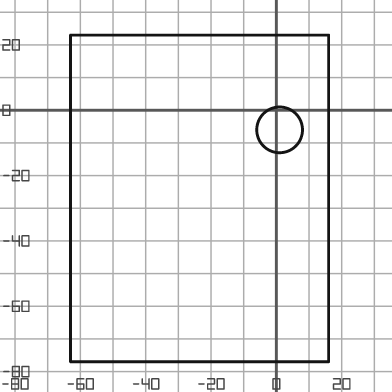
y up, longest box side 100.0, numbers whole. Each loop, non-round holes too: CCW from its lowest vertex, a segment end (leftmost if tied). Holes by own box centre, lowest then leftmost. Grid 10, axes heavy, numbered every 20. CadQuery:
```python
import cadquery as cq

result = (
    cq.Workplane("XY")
    .moveTo(-63.0, -77.0)
    .lineTo(16.0, -77.0)
    .lineTo(16.0, 23.0)
    .lineTo(-63.0, 23.0)
    .close()
    .moveTo(1.0, -6.0)
    .circle(7.0)
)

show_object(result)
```